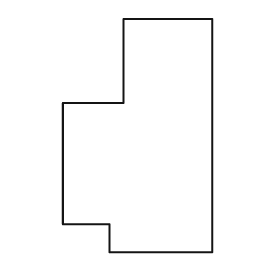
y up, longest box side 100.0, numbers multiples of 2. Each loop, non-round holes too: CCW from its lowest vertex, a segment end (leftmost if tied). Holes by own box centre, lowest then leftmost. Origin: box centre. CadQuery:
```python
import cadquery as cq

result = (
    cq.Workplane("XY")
    .moveTo(-12.0, -50.0)
    .lineTo(32.0, -50.0)
    .lineTo(32.0, 50.0)
    .lineTo(-6.0, 50.0)
    .lineTo(-6.0, 14.0)
    .lineTo(-32.0, 14.0)
    .lineTo(-32.0, -38.0)
    .lineTo(-12.0, -38.0)
    .close()
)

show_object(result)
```